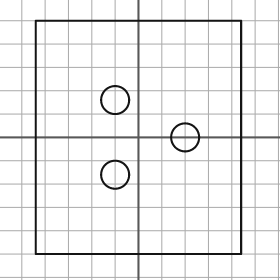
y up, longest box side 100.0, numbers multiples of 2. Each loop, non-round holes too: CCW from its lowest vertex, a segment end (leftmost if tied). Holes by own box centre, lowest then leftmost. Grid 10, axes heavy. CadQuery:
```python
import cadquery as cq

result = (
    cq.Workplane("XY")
    .moveTo(-44.0, -50.0)
    .lineTo(44.0, -50.0)
    .lineTo(44.0, 50.0)
    .lineTo(-44.0, 50.0)
    .close()
    .moveTo(-10.0, -16.0)
    .circle(6.0)
    .moveTo(20.0, 0.0)
    .circle(6.0)
    .moveTo(-10.0, 16.0)
    .circle(6.0)
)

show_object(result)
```